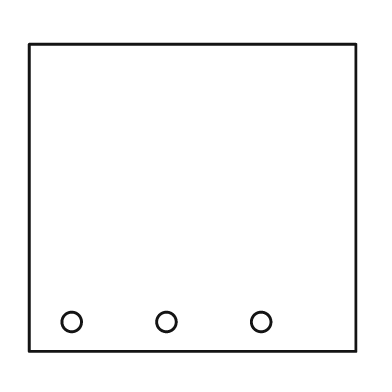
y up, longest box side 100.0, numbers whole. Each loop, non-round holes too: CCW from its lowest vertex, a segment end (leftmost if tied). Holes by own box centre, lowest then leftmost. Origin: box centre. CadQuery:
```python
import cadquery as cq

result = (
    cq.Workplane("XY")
    .moveTo(-50.0, -47.0)
    .lineTo(50.0, -47.0)
    .lineTo(50.0, 47.0)
    .lineTo(-50.0, 47.0)
    .close()
    .moveTo(-37.0, -38.0)
    .circle(3.0)
    .moveTo(-8.0, -38.0)
    .circle(3.0)
    .moveTo(21.0, -38.0)
    .circle(3.0)
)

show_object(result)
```